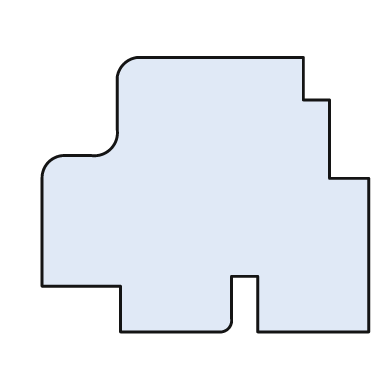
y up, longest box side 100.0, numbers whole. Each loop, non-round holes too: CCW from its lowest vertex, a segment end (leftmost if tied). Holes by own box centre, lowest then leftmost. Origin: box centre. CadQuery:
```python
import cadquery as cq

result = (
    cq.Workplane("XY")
    .moveTo(-26.0, -42.0)
    .lineTo(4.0, -42.0)
    .threePointArc((7.0, -41.0), (8.0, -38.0))
    .lineTo(8.0, -25.0)
    .lineTo(16.0, -25.0)
    .lineTo(16.0, -42.0)
    .lineTo(50.0, -42.0)
    .lineTo(50.0, 5.0)
    .lineTo(38.0, 5.0)
    .lineTo(38.0, 29.0)
    .lineTo(30.0, 29.0)
    .lineTo(30.0, 42.0)
    .lineTo(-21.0, 42.0)
    .threePointArc((-25.0, 40.0), (-27.0, 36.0))
    .lineTo(-27.0, 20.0)
    .threePointArc((-29.0, 14.0), (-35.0, 12.0))
    .lineTo(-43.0, 12.0)
    .threePointArc((-48.0, 10.0), (-50.0, 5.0))
    .lineTo(-50.0, -28.0)
    .lineTo(-26.0, -28.0)
    .close()
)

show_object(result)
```